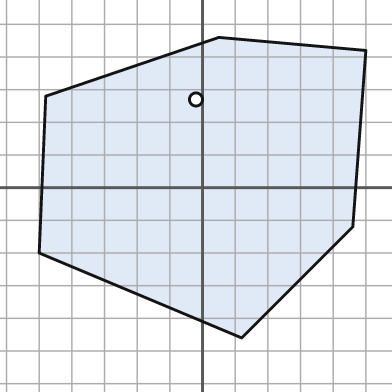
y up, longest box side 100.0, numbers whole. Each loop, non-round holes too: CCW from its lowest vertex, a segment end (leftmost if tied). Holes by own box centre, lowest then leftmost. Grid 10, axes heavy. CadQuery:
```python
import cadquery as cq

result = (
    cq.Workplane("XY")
    .moveTo(12.0, -46.0)
    .lineTo(46.0, -12.0)
    .lineTo(50.0, 42.0)
    .lineTo(5.0, 46.0)
    .lineTo(-48.0, 28.0)
    .lineTo(-50.0, -20.0)
    .close()
    .moveTo(-2.0, 27.0)
    .circle(2.0)
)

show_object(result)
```